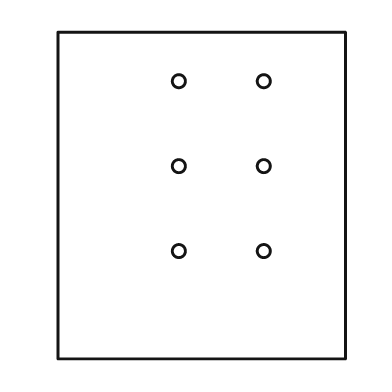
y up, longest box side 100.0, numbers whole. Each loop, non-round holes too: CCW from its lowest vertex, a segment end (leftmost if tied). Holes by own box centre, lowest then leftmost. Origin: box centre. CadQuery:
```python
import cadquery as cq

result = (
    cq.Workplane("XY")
    .moveTo(-44.0, -50.0)
    .lineTo(44.0, -50.0)
    .lineTo(44.0, 50.0)
    .lineTo(-44.0, 50.0)
    .close()
    .moveTo(-7.0, -17.0)
    .circle(2.0)
    .moveTo(19.0, -17.0)
    .circle(2.0)
    .moveTo(-7.0, 9.0)
    .circle(2.0)
    .moveTo(19.0, 9.0)
    .circle(2.0)
    .moveTo(-7.0, 35.0)
    .circle(2.0)
    .moveTo(19.0, 35.0)
    .circle(2.0)
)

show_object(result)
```